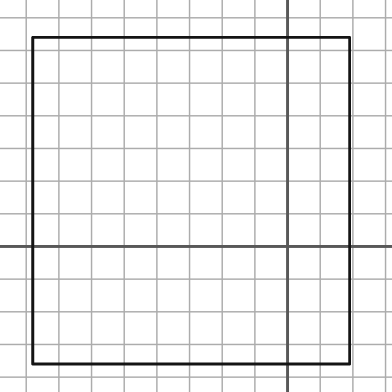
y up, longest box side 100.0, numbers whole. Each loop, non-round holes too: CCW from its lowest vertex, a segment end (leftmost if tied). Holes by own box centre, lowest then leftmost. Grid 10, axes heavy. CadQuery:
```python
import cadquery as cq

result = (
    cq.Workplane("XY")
    .moveTo(-78.0, -36.0)
    .lineTo(19.0, -36.0)
    .lineTo(19.0, 64.0)
    .lineTo(-78.0, 64.0)
    .close()
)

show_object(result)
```